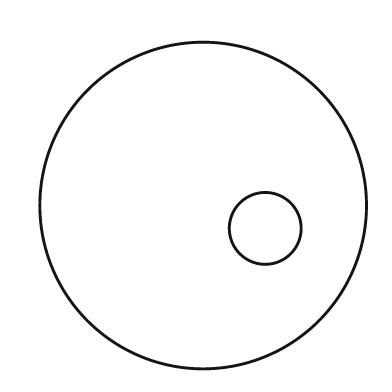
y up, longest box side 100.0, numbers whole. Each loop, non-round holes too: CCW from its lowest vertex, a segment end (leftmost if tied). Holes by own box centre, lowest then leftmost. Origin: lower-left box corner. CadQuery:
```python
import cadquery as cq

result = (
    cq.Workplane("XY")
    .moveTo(50.0, 50.0)
    .circle(50.0)
    .moveTo(69.0, 43.0)
    .circle(11.0)
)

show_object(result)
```